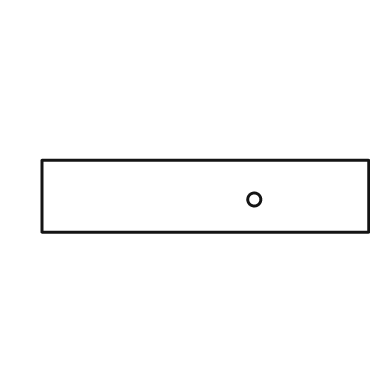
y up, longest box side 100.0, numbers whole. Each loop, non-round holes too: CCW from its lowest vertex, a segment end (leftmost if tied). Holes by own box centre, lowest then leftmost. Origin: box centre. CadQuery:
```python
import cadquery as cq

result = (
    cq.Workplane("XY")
    .moveTo(-50.0, -11.0)
    .lineTo(50.0, -11.0)
    .lineTo(50.0, 11.0)
    .lineTo(-50.0, 11.0)
    .close()
    .moveTo(15.0, -1.0)
    .circle(2.0)
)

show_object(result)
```